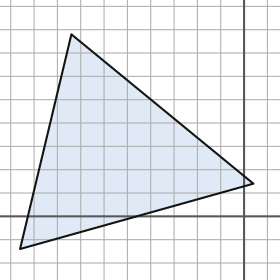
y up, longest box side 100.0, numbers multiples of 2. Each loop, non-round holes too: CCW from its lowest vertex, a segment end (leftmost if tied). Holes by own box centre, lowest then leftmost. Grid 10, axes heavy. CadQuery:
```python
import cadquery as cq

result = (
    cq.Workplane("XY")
    .moveTo(-96.0, -14.0)
    .lineTo(4.0, 14.0)
    .lineTo(-74.0, 78.0)
    .close()
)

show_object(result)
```